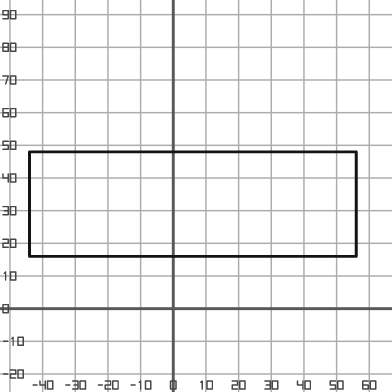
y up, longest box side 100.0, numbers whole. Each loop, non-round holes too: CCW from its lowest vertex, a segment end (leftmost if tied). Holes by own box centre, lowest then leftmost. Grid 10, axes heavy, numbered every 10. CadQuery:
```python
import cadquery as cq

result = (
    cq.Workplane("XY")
    .moveTo(-44.0, 16.0)
    .lineTo(56.0, 16.0)
    .lineTo(56.0, 48.0)
    .lineTo(-44.0, 48.0)
    .close()
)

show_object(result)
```